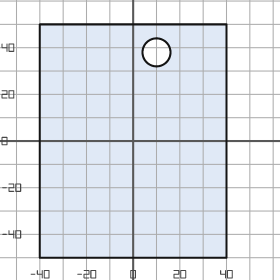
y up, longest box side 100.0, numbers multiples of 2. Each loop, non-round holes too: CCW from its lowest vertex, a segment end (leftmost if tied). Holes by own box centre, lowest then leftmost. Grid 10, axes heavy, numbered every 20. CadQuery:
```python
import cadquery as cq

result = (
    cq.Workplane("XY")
    .moveTo(-40.0, -50.0)
    .lineTo(40.0, -50.0)
    .lineTo(40.0, 50.0)
    .lineTo(-40.0, 50.0)
    .close()
    .moveTo(10.0, 38.0)
    .circle(6.0)
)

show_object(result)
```